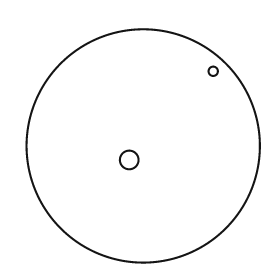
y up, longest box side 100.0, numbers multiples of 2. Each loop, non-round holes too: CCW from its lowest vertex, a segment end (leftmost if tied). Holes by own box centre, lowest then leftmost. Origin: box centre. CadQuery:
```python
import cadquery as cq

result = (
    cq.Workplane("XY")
    .moveTo(0.0, 0.0)
    .circle(50.0)
    .moveTo(-6.0, -6.0)
    .circle(4.0)
    .moveTo(30.0, 32.0)
    .circle(2.0)
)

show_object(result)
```